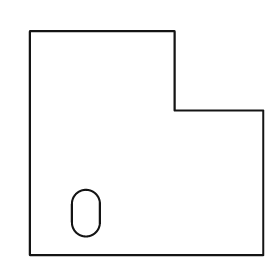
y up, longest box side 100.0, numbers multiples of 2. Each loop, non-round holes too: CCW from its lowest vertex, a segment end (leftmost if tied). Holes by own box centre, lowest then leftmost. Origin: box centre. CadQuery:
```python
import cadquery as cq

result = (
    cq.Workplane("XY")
    .moveTo(-50.0, -48.0)
    .lineTo(50.0, -48.0)
    .lineTo(50.0, 14.0)
    .lineTo(12.0, 14.0)
    .lineTo(12.0, 48.0)
    .lineTo(-50.0, 48.0)
    .close()
    .moveTo(-32.0, -34.0)
    .threePointArc((-26.0, -40.0), (-20.0, -34.0))
    .lineTo(-20.0, -26.0)
    .threePointArc((-26.0, -20.0), (-32.0, -26.0))
    .close()
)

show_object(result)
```